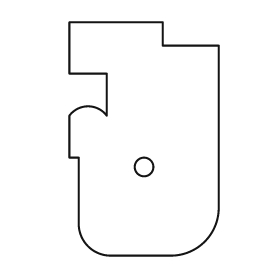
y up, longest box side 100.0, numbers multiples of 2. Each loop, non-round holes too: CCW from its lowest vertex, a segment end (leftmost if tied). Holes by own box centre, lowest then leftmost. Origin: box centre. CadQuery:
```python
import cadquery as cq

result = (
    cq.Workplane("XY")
    .moveTo(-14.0, -50.0)
    .lineTo(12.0, -50.0)
    .threePointArc((26.0, -44.0), (32.0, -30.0))
    .lineTo(32.0, 40.0)
    .lineTo(8.0, 40.0)
    .lineTo(8.0, 50.0)
    .lineTo(-32.0, 50.0)
    .lineTo(-32.0, 28.0)
    .lineTo(-16.0, 28.0)
    .lineTo(-16.0, 10.0)
    .threePointArc((-24.0, 14.0), (-32.0, 10.0))
    .lineTo(-32.0, -8.0)
    .lineTo(-28.0, -8.0)
    .lineTo(-28.0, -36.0)
    .threePointArc((-24.0, -46.0), (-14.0, -50.0))
    .close()
    .moveTo(0.0, -12.0)
    .circle(4.0)
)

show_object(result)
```